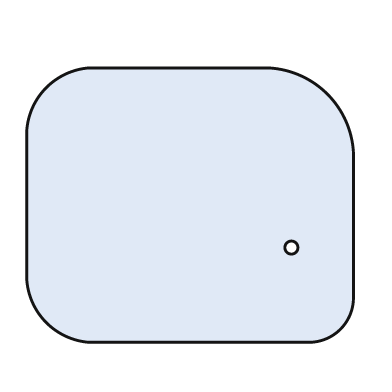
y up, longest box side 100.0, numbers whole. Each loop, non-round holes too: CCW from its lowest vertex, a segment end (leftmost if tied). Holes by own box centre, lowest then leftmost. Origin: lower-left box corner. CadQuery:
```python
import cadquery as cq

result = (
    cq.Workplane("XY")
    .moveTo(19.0, 0.0)
    .lineTo(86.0, 0.0)
    .threePointArc((96.0, 4.0), (100.0, 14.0))
    .lineTo(100.0, 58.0)
    .threePointArc((92.0, 76.0), (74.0, 84.0))
    .lineTo(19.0, 84.0)
    .threePointArc((6.0, 78.0), (0.0, 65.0))
    .lineTo(0.0, 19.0)
    .threePointArc((6.0, 6.0), (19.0, 0.0))
    .close()
    .moveTo(81.0, 29.0)
    .circle(2.0)
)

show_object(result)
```